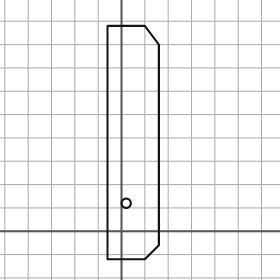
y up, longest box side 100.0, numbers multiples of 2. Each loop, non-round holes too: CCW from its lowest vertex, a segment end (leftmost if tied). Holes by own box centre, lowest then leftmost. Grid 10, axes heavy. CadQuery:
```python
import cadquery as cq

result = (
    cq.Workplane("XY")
    .moveTo(-6.0, -12.0)
    .lineTo(10.0, -12.0)
    .lineTo(16.0, -6.0)
    .lineTo(16.0, 80.0)
    .lineTo(10.0, 88.0)
    .lineTo(-6.0, 88.0)
    .close()
    .moveTo(2.0, 12.0)
    .circle(2.0)
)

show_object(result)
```